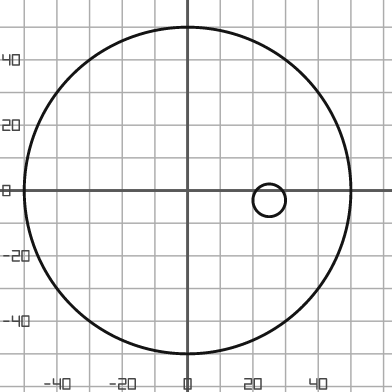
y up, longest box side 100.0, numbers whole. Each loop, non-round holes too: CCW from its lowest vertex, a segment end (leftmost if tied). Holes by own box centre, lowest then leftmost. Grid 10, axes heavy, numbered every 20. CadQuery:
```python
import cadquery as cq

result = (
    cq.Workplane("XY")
    .moveTo(0.0, 0.0)
    .circle(50.0)
    .moveTo(25.0, -3.0)
    .circle(5.0)
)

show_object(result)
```